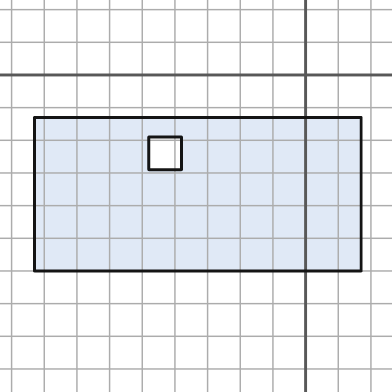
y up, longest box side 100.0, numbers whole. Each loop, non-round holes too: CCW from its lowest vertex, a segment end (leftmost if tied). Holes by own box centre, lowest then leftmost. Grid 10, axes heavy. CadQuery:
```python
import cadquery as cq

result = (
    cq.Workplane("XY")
    .moveTo(-83.0, -60.0)
    .lineTo(17.0, -60.0)
    .lineTo(17.0, -13.0)
    .lineTo(-83.0, -13.0)
    .close()
    .moveTo(-48.0, -29.0)
    .lineTo(-38.0, -29.0)
    .lineTo(-38.0, -19.0)
    .lineTo(-48.0, -19.0)
    .close()
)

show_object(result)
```